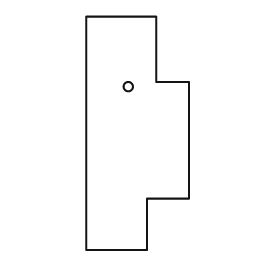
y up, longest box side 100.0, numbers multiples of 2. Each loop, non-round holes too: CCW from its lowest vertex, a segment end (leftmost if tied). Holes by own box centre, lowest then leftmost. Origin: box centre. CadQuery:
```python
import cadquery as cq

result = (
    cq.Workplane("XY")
    .moveTo(-22.0, -50.0)
    .lineTo(4.0, -50.0)
    .lineTo(4.0, -28.0)
    .lineTo(22.0, -28.0)
    .lineTo(22.0, 22.0)
    .lineTo(8.0, 22.0)
    .lineTo(8.0, 50.0)
    .lineTo(-22.0, 50.0)
    .close()
    .moveTo(-4.0, 20.0)
    .circle(2.0)
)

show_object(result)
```